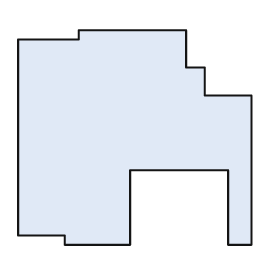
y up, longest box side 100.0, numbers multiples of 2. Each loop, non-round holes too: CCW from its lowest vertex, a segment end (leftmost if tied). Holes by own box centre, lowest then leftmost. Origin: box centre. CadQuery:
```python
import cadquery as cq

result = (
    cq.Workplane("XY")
    .moveTo(-30.0, -46.0)
    .lineTo(-2.0, -46.0)
    .lineTo(-2.0, -14.0)
    .lineTo(40.0, -14.0)
    .lineTo(40.0, -46.0)
    .lineTo(50.0, -46.0)
    .lineTo(50.0, 18.0)
    .lineTo(30.0, 18.0)
    .lineTo(30.0, 30.0)
    .lineTo(22.0, 30.0)
    .lineTo(22.0, 46.0)
    .lineTo(-24.0, 46.0)
    .lineTo(-24.0, 42.0)
    .lineTo(-50.0, 42.0)
    .lineTo(-50.0, -42.0)
    .lineTo(-30.0, -42.0)
    .close()
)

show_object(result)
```